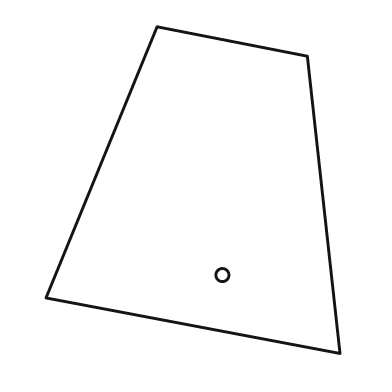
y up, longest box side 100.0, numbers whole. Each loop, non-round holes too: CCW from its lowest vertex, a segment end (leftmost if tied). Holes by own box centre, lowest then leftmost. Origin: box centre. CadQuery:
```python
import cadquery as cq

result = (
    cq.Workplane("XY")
    .moveTo(45.0, -50.0)
    .lineTo(35.0, 41.0)
    .lineTo(-11.0, 50.0)
    .lineTo(-45.0, -33.0)
    .close()
    .moveTo(9.0, -26.0)
    .circle(2.0)
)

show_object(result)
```